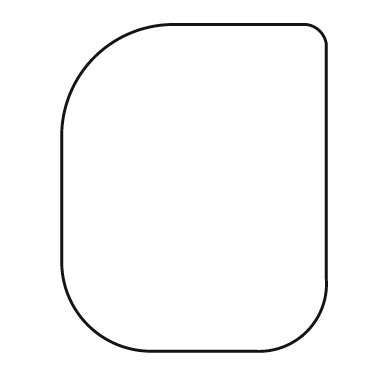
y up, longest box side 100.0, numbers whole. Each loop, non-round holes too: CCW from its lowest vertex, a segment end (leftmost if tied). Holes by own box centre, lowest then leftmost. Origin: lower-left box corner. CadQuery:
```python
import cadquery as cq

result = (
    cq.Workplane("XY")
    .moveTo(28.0, 0.0)
    .lineTo(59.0, 0.0)
    .threePointArc((75.0, 6.0), (81.0, 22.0))
    .lineTo(81.0, 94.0)
    .threePointArc((79.0, 98.0), (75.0, 100.0))
    .lineTo(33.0, 100.0)
    .threePointArc((10.0, 90.0), (0.0, 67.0))
    .lineTo(0.0, 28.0)
    .threePointArc((8.0, 8.0), (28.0, 0.0))
    .close()
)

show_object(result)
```